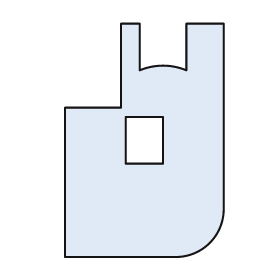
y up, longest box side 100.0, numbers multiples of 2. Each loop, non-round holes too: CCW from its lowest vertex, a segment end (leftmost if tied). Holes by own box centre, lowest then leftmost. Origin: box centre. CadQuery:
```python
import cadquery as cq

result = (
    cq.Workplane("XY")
    .moveTo(-34.0, -50.0)
    .lineTo(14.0, -50.0)
    .threePointArc((28.0, -44.0), (34.0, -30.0))
    .lineTo(34.0, 50.0)
    .lineTo(18.0, 50.0)
    .lineTo(18.0, 30.0)
    .threePointArc((8.0, 32.0), (-2.0, 30.0))
    .lineTo(-2.0, 50.0)
    .lineTo(-10.0, 50.0)
    .lineTo(-10.0, 14.0)
    .lineTo(-34.0, 14.0)
    .close()
    .moveTo(-8.0, -10.0)
    .lineTo(8.0, -10.0)
    .lineTo(8.0, 10.0)
    .lineTo(-8.0, 10.0)
    .close()
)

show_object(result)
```